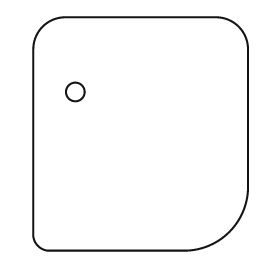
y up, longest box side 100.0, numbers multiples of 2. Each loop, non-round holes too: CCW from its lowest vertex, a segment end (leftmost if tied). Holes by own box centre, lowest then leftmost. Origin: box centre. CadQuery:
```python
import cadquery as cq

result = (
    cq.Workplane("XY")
    .moveTo(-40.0, -50.0)
    .lineTo(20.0, -50.0)
    .threePointArc((38.0, -42.0), (46.0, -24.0))
    .lineTo(46.0, 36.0)
    .threePointArc((42.0, 46.0), (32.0, 50.0))
    .lineTo(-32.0, 50.0)
    .threePointArc((-42.0, 46.0), (-46.0, 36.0))
    .lineTo(-46.0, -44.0)
    .threePointArc((-44.0, -48.0), (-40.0, -50.0))
    .close()
    .moveTo(-28.0, 18.0)
    .circle(4.0)
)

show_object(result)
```